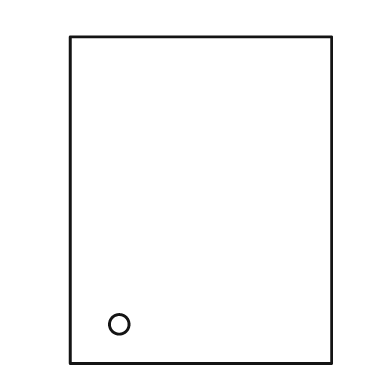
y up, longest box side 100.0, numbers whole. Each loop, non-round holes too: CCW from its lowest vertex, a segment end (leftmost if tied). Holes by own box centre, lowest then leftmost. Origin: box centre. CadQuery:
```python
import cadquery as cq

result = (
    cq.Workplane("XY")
    .moveTo(-40.0, -50.0)
    .lineTo(40.0, -50.0)
    .lineTo(40.0, 50.0)
    .lineTo(-40.0, 50.0)
    .close()
    .moveTo(-25.0, -38.0)
    .circle(3.0)
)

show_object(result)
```